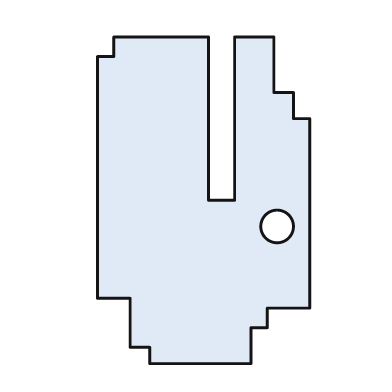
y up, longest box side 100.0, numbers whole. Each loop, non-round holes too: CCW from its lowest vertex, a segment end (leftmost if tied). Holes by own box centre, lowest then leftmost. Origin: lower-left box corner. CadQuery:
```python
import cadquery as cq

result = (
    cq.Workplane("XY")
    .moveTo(16.0, 0.0)
    .lineTo(47.0, 0.0)
    .lineTo(47.0, 11.0)
    .lineTo(52.0, 11.0)
    .lineTo(52.0, 17.0)
    .lineTo(65.0, 17.0)
    .lineTo(65.0, 75.0)
    .lineTo(60.0, 75.0)
    .lineTo(60.0, 83.0)
    .lineTo(54.0, 83.0)
    .lineTo(54.0, 100.0)
    .lineTo(42.0, 100.0)
    .lineTo(42.0, 50.0)
    .lineTo(34.0, 50.0)
    .lineTo(34.0, 100.0)
    .lineTo(5.0, 100.0)
    .lineTo(5.0, 94.0)
    .lineTo(0.0, 94.0)
    .lineTo(0.0, 20.0)
    .lineTo(10.0, 20.0)
    .lineTo(10.0, 5.0)
    .lineTo(16.0, 5.0)
    .close()
    .moveTo(55.0, 42.0)
    .circle(5.0)
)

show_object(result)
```